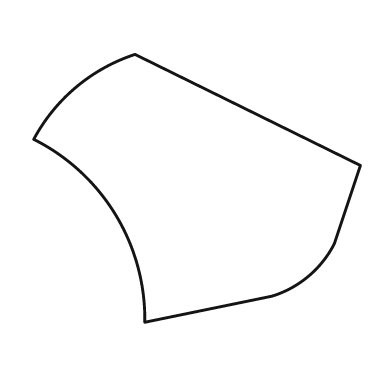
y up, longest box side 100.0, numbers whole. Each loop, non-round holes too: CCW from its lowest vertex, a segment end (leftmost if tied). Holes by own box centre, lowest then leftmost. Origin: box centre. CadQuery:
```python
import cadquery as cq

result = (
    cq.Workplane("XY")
    .moveTo(-16.0, -41.0)
    .lineTo(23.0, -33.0)
    .threePointArc((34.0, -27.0), (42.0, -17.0))
    .lineTo(50.0, 7.0)
    .lineTo(-19.0, 41.0)
    .threePointArc((-37.0, 31.0), (-50.0, 15.0))
    .threePointArc((-25.0, -8.0), (-16.0, -41.0))
    .close()
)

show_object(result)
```